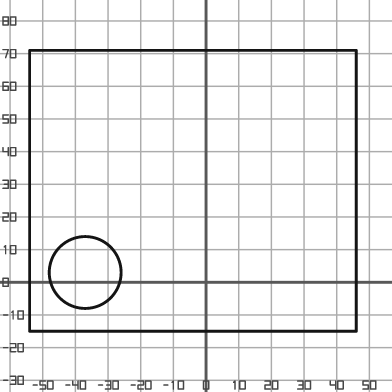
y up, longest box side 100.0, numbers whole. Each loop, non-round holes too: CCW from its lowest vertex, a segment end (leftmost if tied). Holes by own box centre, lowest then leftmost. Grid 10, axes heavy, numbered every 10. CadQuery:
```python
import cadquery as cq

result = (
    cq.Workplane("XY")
    .moveTo(-54.0, -15.0)
    .lineTo(46.0, -15.0)
    .lineTo(46.0, 71.0)
    .lineTo(-54.0, 71.0)
    .close()
    .moveTo(-37.0, 3.0)
    .circle(11.0)
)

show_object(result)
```